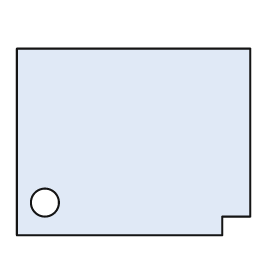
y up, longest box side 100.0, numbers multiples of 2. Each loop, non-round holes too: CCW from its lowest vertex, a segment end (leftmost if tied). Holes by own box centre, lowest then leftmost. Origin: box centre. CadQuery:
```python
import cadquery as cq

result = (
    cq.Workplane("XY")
    .moveTo(-50.0, -40.0)
    .lineTo(38.0, -40.0)
    .lineTo(38.0, -32.0)
    .lineTo(50.0, -32.0)
    .lineTo(50.0, 40.0)
    .lineTo(-50.0, 40.0)
    .close()
    .moveTo(-38.0, -26.0)
    .circle(6.0)
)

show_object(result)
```